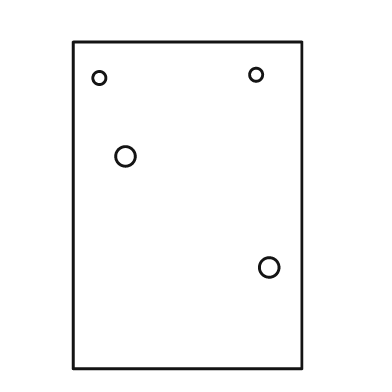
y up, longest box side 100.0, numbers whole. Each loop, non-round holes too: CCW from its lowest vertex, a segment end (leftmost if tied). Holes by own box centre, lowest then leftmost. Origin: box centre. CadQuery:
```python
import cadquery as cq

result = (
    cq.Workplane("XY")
    .moveTo(-35.0, -50.0)
    .lineTo(35.0, -50.0)
    .lineTo(35.0, 50.0)
    .lineTo(-35.0, 50.0)
    .close()
    .moveTo(25.0, -19.0)
    .circle(3.0)
    .moveTo(-19.0, 15.0)
    .circle(3.0)
    .moveTo(-27.0, 39.0)
    .circle(2.0)
    .moveTo(21.0, 40.0)
    .circle(2.0)
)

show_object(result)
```